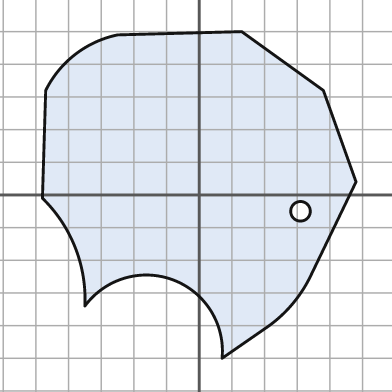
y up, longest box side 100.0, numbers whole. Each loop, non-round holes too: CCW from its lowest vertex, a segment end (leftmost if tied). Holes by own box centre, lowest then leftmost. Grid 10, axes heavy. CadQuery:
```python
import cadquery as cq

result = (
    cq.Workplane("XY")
    .moveTo(7.0, -50.0)
    .lineTo(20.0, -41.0)
    .threePointArc((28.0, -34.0), (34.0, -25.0))
    .lineTo(48.0, 4.0)
    .lineTo(38.0, 32.0)
    .lineTo(13.0, 50.0)
    .lineTo(-25.0, 49.0)
    .threePointArc((-38.0, 43.0), (-47.0, 32.0))
    .lineTo(-48.0, -1.0)
    .threePointArc((-38.0, -16.0), (-35.0, -34.0))
    .threePointArc((-8.0, -26.0), (7.0, -50.0))
    .close()
    .moveTo(31.0, -5.0)
    .circle(3.0)
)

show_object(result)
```